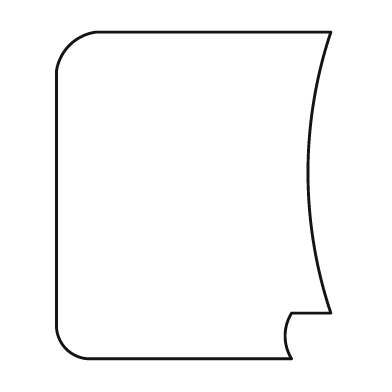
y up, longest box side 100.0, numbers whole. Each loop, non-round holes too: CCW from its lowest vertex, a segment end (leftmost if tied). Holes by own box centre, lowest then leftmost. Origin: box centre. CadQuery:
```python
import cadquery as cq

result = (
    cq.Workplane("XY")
    .moveTo(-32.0, -50.0)
    .lineTo(30.0, -50.0)
    .threePointArc((28.0, -43.0), (30.0, -36.0))
    .lineTo(42.0, -36.0)
    .threePointArc((35.0, 7.0), (42.0, 50.0))
    .lineTo(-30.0, 50.0)
    .threePointArc((-38.0, 46.0), (-42.0, 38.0))
    .lineTo(-42.0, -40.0)
    .threePointArc((-39.0, -47.0), (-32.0, -50.0))
    .close()
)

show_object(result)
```